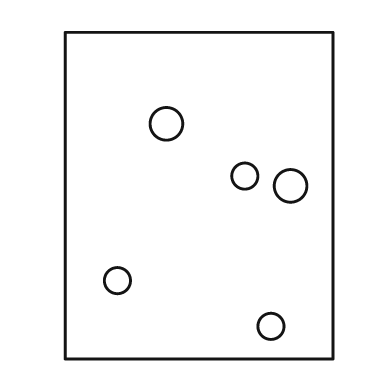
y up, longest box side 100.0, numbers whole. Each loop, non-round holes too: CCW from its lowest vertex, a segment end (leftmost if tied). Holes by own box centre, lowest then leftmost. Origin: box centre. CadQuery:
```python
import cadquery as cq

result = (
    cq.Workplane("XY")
    .moveTo(-41.0, -50.0)
    .lineTo(41.0, -50.0)
    .lineTo(41.0, 50.0)
    .lineTo(-41.0, 50.0)
    .close()
    .moveTo(22.0, -40.0)
    .circle(4.0)
    .moveTo(-25.0, -26.0)
    .circle(4.0)
    .moveTo(28.0, 3.0)
    .circle(5.0)
    .moveTo(14.0, 6.0)
    .circle(4.0)
    .moveTo(-10.0, 22.0)
    .circle(5.0)
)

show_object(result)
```